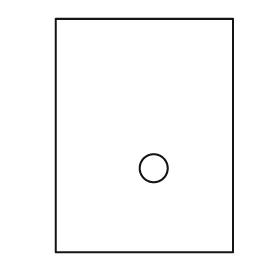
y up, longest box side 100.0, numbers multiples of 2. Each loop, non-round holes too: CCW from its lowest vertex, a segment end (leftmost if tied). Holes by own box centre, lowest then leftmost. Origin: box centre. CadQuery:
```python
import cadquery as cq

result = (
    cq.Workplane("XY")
    .moveTo(-38.0, -50.0)
    .lineTo(38.0, -50.0)
    .lineTo(38.0, 50.0)
    .lineTo(-38.0, 50.0)
    .close()
    .moveTo(4.0, -14.0)
    .circle(6.0)
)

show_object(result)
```